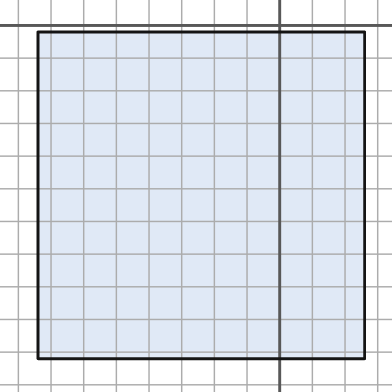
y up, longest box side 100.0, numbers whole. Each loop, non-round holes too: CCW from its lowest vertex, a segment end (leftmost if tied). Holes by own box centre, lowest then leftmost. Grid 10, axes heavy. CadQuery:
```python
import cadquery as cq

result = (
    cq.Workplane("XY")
    .moveTo(-74.0, -102.0)
    .lineTo(26.0, -102.0)
    .lineTo(26.0, -2.0)
    .lineTo(-74.0, -2.0)
    .close()
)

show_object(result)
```